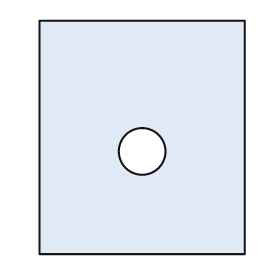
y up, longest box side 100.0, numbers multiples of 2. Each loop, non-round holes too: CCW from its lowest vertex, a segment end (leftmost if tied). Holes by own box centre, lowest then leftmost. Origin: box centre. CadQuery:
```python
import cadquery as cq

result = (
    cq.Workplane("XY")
    .moveTo(-44.0, -50.0)
    .lineTo(44.0, -50.0)
    .lineTo(44.0, 50.0)
    .lineTo(-44.0, 50.0)
    .close()
    .moveTo(0.0, -6.0)
    .circle(10.0)
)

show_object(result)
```